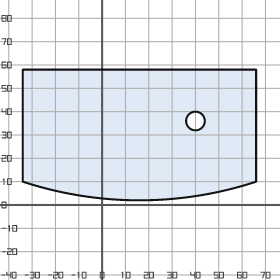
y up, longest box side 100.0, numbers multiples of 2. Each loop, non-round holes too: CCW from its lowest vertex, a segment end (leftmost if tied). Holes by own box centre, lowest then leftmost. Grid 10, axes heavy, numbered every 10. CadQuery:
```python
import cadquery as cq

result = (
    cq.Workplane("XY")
    .moveTo(-34.0, 10.0)
    .threePointArc((16.0, 2.0), (66.0, 10.0))
    .lineTo(66.0, 58.0)
    .lineTo(-34.0, 58.0)
    .close()
    .moveTo(40.0, 36.0)
    .circle(4.0)
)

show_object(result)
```